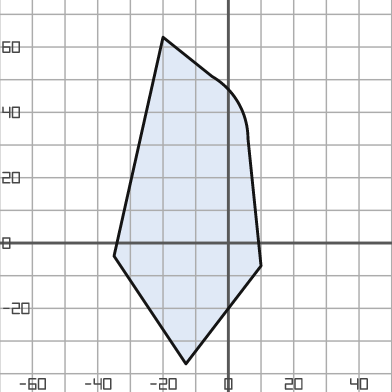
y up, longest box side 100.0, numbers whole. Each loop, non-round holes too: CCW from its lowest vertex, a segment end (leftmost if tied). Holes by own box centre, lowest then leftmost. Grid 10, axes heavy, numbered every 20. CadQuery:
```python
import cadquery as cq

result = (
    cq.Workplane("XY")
    .moveTo(-13.0, -37.0)
    .lineTo(10.0, -7.0)
    .lineTo(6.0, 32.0)
    .threePointArc((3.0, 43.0), (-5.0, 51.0))
    .lineTo(-20.0, 63.0)
    .lineTo(-35.0, -4.0)
    .close()
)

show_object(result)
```